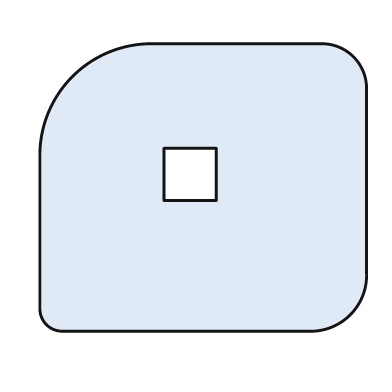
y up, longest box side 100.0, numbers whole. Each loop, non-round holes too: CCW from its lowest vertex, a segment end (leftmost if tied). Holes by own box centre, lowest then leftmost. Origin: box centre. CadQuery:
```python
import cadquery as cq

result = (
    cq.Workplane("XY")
    .moveTo(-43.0, -44.0)
    .lineTo(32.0, -44.0)
    .threePointArc((45.0, -39.0), (50.0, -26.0))
    .lineTo(50.0, 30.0)
    .threePointArc((46.0, 40.0), (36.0, 44.0))
    .lineTo(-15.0, 44.0)
    .threePointArc((-40.0, 34.0), (-50.0, 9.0))
    .lineTo(-50.0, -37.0)
    .threePointArc((-48.0, -42.0), (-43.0, -44.0))
    .close()
    .moveTo(-12.0, -4.0)
    .lineTo(4.0, -4.0)
    .lineTo(4.0, 12.0)
    .lineTo(-12.0, 12.0)
    .close()
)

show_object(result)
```